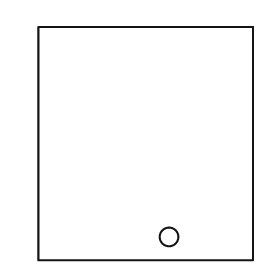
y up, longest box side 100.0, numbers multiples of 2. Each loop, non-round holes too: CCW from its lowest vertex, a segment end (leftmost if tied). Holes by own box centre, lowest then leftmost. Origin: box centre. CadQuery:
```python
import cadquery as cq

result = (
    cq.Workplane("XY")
    .moveTo(-46.0, -50.0)
    .lineTo(46.0, -50.0)
    .lineTo(46.0, 50.0)
    .lineTo(-46.0, 50.0)
    .close()
    .moveTo(10.0, -40.0)
    .circle(4.0)
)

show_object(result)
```